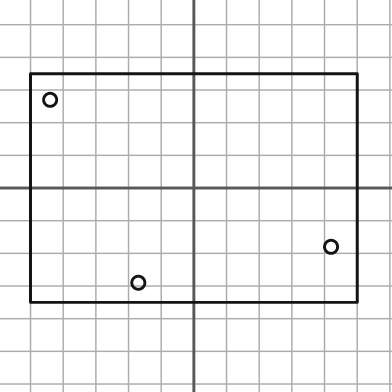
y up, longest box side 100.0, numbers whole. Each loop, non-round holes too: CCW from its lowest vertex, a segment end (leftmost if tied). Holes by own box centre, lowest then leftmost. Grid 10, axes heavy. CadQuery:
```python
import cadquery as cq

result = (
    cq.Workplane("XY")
    .moveTo(-50.0, -35.0)
    .lineTo(50.0, -35.0)
    .lineTo(50.0, 35.0)
    .lineTo(-50.0, 35.0)
    .close()
    .moveTo(-17.0, -29.0)
    .circle(2.0)
    .moveTo(42.0, -18.0)
    .circle(2.0)
    .moveTo(-44.0, 27.0)
    .circle(2.0)
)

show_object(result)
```